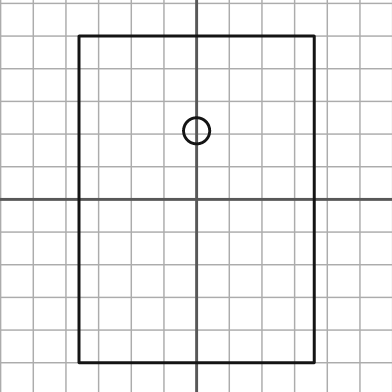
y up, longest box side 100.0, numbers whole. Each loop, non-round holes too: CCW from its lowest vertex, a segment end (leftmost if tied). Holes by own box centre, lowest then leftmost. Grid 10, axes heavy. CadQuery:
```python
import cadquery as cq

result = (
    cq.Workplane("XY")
    .moveTo(-36.0, -50.0)
    .lineTo(36.0, -50.0)
    .lineTo(36.0, 50.0)
    .lineTo(-36.0, 50.0)
    .close()
    .moveTo(0.0, 21.0)
    .circle(4.0)
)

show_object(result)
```